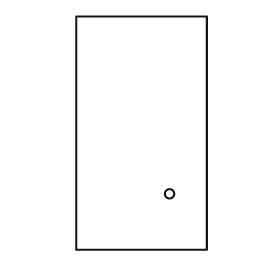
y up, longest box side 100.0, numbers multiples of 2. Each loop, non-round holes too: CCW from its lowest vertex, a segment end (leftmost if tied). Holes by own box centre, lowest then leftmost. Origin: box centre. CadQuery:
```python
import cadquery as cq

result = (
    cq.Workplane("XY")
    .moveTo(-28.0, -50.0)
    .lineTo(28.0, -50.0)
    .lineTo(28.0, 50.0)
    .lineTo(-28.0, 50.0)
    .close()
    .moveTo(12.0, -26.0)
    .circle(2.0)
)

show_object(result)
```